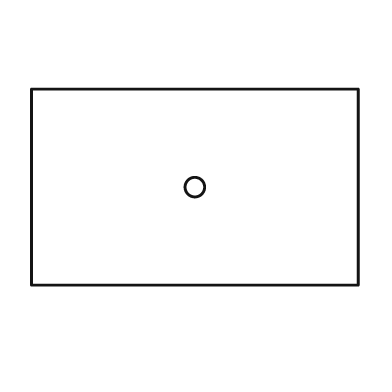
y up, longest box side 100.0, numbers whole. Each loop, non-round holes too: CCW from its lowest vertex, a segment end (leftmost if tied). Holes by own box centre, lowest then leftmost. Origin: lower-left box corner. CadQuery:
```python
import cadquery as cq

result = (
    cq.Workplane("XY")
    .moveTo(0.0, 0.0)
    .lineTo(100.0, 0.0)
    .lineTo(100.0, 60.0)
    .lineTo(0.0, 60.0)
    .close()
    .moveTo(50.0, 30.0)
    .circle(3.0)
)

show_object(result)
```